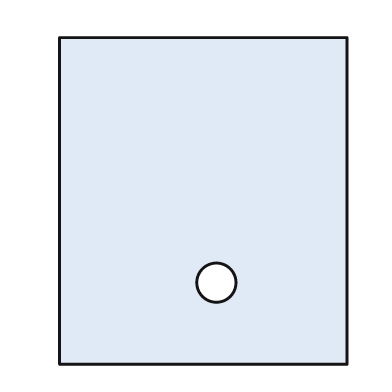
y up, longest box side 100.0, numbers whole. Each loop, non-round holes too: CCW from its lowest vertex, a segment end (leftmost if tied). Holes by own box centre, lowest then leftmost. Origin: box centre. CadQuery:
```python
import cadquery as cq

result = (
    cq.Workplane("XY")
    .moveTo(-44.0, -50.0)
    .lineTo(44.0, -50.0)
    .lineTo(44.0, 50.0)
    .lineTo(-44.0, 50.0)
    .close()
    .moveTo(4.0, -25.0)
    .circle(6.0)
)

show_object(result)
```